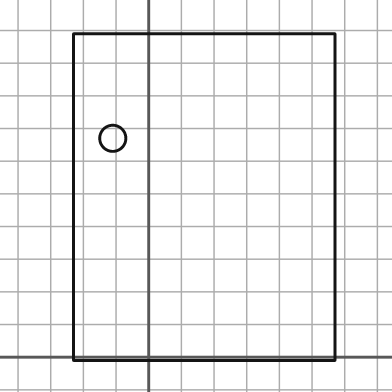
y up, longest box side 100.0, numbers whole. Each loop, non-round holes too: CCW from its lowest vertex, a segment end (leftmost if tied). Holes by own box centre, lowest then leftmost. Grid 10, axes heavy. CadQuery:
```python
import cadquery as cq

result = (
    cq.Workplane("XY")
    .moveTo(-23.0, -1.0)
    .lineTo(57.0, -1.0)
    .lineTo(57.0, 99.0)
    .lineTo(-23.0, 99.0)
    .close()
    .moveTo(-11.0, 67.0)
    .circle(4.0)
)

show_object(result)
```